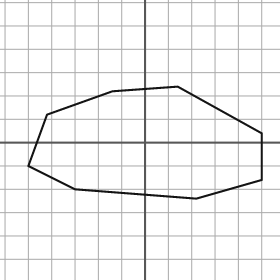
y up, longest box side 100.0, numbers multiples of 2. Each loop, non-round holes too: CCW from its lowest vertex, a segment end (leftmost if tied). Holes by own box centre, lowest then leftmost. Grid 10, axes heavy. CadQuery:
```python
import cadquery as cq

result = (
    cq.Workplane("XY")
    .moveTo(22.0, -24.0)
    .lineTo(50.0, -16.0)
    .lineTo(50.0, 4.0)
    .lineTo(14.0, 24.0)
    .lineTo(-14.0, 22.0)
    .lineTo(-42.0, 12.0)
    .lineTo(-50.0, -10.0)
    .lineTo(-30.0, -20.0)
    .close()
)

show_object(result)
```